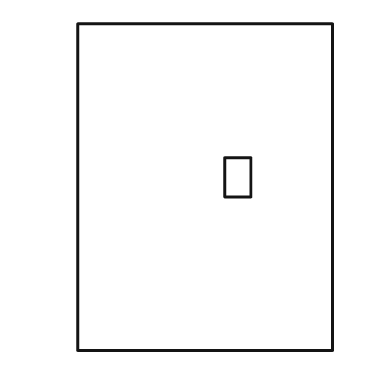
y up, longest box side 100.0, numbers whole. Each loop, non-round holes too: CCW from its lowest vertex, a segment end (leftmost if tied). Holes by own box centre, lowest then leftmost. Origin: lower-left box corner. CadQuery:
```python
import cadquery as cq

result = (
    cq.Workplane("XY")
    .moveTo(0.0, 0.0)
    .lineTo(78.0, 0.0)
    .lineTo(78.0, 100.0)
    .lineTo(0.0, 100.0)
    .close()
    .moveTo(45.0, 47.0)
    .lineTo(53.0, 47.0)
    .lineTo(53.0, 59.0)
    .lineTo(45.0, 59.0)
    .close()
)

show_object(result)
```